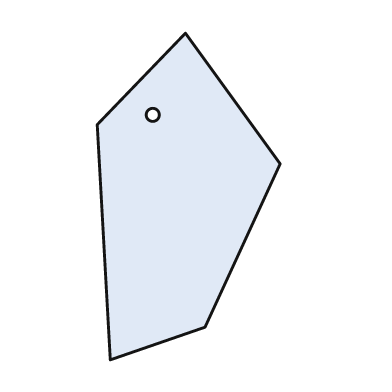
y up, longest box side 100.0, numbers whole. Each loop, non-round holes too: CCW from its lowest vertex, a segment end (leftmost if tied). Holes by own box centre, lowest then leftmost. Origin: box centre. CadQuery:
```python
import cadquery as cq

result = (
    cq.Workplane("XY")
    .moveTo(-24.0, -50.0)
    .lineTo(5.0, -40.0)
    .lineTo(28.0, 10.0)
    .lineTo(-1.0, 50.0)
    .lineTo(-28.0, 22.0)
    .close()
    .moveTo(-11.0, 25.0)
    .circle(2.0)
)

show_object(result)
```